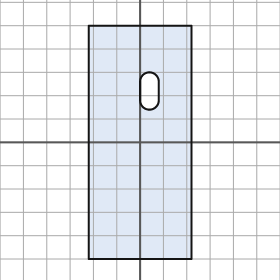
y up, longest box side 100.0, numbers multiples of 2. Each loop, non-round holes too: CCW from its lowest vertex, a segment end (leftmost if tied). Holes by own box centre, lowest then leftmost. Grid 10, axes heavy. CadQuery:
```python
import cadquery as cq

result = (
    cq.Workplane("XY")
    .moveTo(-22.0, -50.0)
    .lineTo(22.0, -50.0)
    .lineTo(22.0, 50.0)
    .lineTo(-22.0, 50.0)
    .close()
    .moveTo(0.0, 18.0)
    .threePointArc((4.0, 14.0), (8.0, 18.0))
    .lineTo(8.0, 26.0)
    .threePointArc((4.0, 30.0), (0.0, 26.0))
    .close()
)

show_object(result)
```